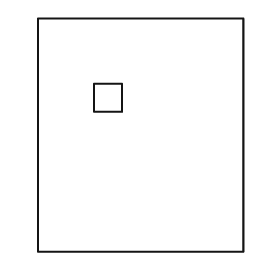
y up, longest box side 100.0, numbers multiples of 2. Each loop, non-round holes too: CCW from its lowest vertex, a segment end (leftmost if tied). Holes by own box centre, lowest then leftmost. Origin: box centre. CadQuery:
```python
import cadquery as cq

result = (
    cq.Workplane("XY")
    .moveTo(-44.0, -50.0)
    .lineTo(44.0, -50.0)
    .lineTo(44.0, 50.0)
    .lineTo(-44.0, 50.0)
    .close()
    .moveTo(-20.0, 10.0)
    .lineTo(-8.0, 10.0)
    .lineTo(-8.0, 22.0)
    .lineTo(-20.0, 22.0)
    .close()
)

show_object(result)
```